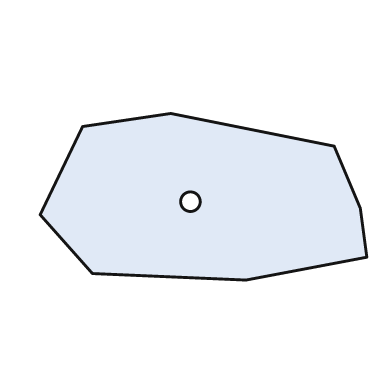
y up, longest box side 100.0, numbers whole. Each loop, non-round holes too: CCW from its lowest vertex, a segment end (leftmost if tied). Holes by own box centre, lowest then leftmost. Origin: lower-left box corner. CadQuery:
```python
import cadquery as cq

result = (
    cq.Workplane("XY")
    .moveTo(63.0, 0.0)
    .lineTo(100.0, 7.0)
    .lineTo(98.0, 22.0)
    .lineTo(90.0, 41.0)
    .lineTo(40.0, 51.0)
    .lineTo(13.0, 47.0)
    .lineTo(0.0, 20.0)
    .lineTo(16.0, 2.0)
    .close()
    .moveTo(46.0, 24.0)
    .circle(3.0)
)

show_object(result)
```